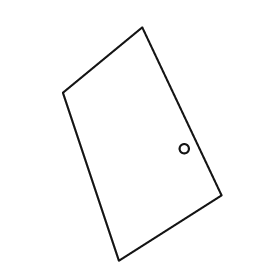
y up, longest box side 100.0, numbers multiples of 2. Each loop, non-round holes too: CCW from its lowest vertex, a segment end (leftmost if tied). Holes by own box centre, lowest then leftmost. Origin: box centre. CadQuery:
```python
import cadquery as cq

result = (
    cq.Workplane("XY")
    .moveTo(-10.0, -50.0)
    .lineTo(34.0, -22.0)
    .lineTo(0.0, 50.0)
    .lineTo(-34.0, 22.0)
    .close()
    .moveTo(18.0, -2.0)
    .circle(2.0)
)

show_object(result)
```